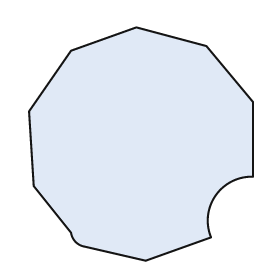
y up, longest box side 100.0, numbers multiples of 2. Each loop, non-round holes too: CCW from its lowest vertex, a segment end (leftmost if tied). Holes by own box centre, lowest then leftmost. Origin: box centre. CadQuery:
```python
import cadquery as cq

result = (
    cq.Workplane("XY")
    .moveTo(2.0, -50.0)
    .lineTo(30.0, -40.0)
    .threePointArc((32.0, -22.0), (48.0, -14.0))
    .lineTo(48.0, 18.0)
    .lineTo(28.0, 42.0)
    .lineTo(-2.0, 50.0)
    .lineTo(-30.0, 40.0)
    .lineTo(-48.0, 14.0)
    .lineTo(-46.0, -18.0)
    .lineTo(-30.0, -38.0)
    .threePointArc((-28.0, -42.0), (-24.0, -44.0))
    .close()
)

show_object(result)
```